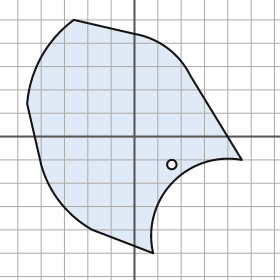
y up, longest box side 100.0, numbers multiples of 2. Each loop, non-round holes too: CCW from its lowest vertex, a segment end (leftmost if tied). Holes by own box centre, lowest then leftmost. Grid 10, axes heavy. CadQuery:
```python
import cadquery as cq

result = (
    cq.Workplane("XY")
    .moveTo(8.0, -50.0)
    .threePointArc((16.0, -20.0), (46.0, -10.0))
    .lineTo(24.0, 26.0)
    .threePointArc((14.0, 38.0), (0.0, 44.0))
    .lineTo(-26.0, 50.0)
    .threePointArc((-40.0, 34.0), (-46.0, 14.0))
    .lineTo(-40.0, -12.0)
    .threePointArc((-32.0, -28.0), (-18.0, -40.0))
    .close()
    .moveTo(16.0, -12.0)
    .circle(2.0)
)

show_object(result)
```